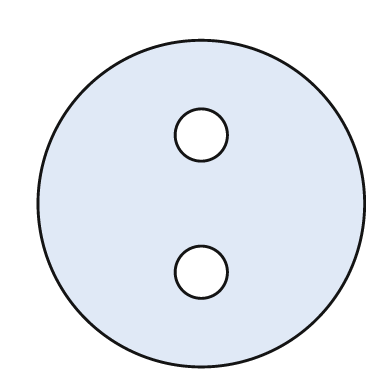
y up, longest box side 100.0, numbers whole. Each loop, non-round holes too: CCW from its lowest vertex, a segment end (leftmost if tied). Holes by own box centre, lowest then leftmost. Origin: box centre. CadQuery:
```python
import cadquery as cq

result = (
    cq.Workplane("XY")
    .moveTo(0.0, 0.0)
    .circle(50.0)
    .moveTo(0.0, -21.0)
    .circle(8.0)
    .moveTo(0.0, 21.0)
    .circle(8.0)
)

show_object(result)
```